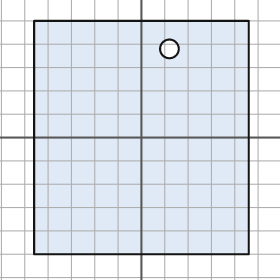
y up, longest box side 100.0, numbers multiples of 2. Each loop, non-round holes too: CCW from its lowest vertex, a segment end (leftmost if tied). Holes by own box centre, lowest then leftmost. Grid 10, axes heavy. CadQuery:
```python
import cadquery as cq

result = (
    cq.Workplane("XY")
    .moveTo(-46.0, -50.0)
    .lineTo(46.0, -50.0)
    .lineTo(46.0, 50.0)
    .lineTo(-46.0, 50.0)
    .close()
    .moveTo(12.0, 38.0)
    .circle(4.0)
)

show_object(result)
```